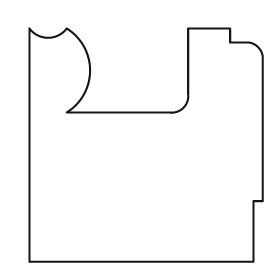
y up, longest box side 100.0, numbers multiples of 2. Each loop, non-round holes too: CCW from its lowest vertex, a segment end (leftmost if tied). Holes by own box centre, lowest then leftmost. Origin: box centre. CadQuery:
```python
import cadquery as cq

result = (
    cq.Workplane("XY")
    .moveTo(-50.0, -50.0)
    .lineTo(46.0, -50.0)
    .lineTo(46.0, -24.0)
    .lineTo(50.0, -24.0)
    .lineTo(50.0, 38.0)
    .threePointArc((48.0, 42.0), (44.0, 44.0))
    .lineTo(36.0, 44.0)
    .lineTo(36.0, 50.0)
    .lineTo(18.0, 50.0)
    .lineTo(18.0, 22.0)
    .threePointArc((16.0, 16.0), (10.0, 14.0))
    .lineTo(-34.0, 14.0)
    .threePointArc((-24.0, 32.0), (-34.0, 50.0))
    .threePointArc((-42.0, 46.0), (-50.0, 50.0))
    .close()
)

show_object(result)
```